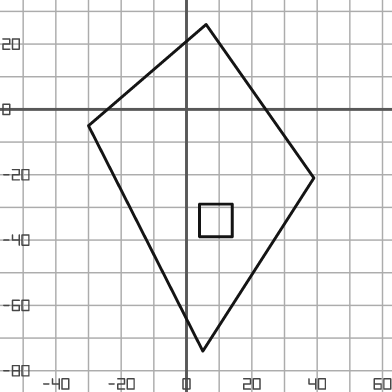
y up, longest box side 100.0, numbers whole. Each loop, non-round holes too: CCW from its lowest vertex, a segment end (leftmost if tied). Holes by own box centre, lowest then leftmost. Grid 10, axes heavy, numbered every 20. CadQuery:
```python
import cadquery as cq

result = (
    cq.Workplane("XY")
    .moveTo(5.0, -74.0)
    .lineTo(39.0, -21.0)
    .lineTo(6.0, 26.0)
    .lineTo(-30.0, -5.0)
    .close()
    .moveTo(4.0, -39.0)
    .lineTo(14.0, -39.0)
    .lineTo(14.0, -29.0)
    .lineTo(4.0, -29.0)
    .close()
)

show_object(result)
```